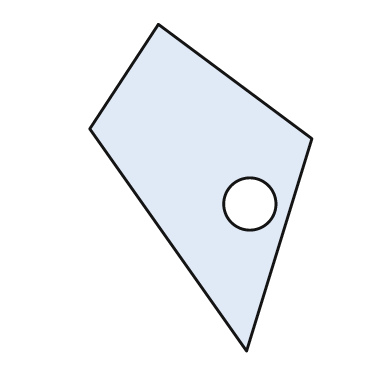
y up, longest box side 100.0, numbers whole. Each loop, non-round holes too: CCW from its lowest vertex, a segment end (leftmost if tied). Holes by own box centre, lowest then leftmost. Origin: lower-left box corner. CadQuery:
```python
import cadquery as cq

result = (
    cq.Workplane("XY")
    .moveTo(48.0, 0.0)
    .lineTo(68.0, 65.0)
    .lineTo(21.0, 100.0)
    .lineTo(0.0, 68.0)
    .close()
    .moveTo(49.0, 45.0)
    .circle(8.0)
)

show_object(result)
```